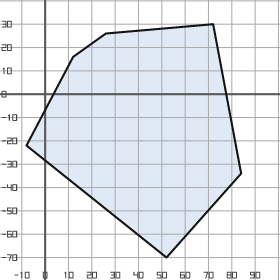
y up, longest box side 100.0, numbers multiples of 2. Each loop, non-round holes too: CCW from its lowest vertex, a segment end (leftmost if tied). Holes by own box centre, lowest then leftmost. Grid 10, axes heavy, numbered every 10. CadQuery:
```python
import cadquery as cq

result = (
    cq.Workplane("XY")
    .moveTo(52.0, -70.0)
    .lineTo(84.0, -34.0)
    .lineTo(72.0, 30.0)
    .lineTo(26.0, 26.0)
    .lineTo(12.0, 16.0)
    .lineTo(-8.0, -22.0)
    .close()
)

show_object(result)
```